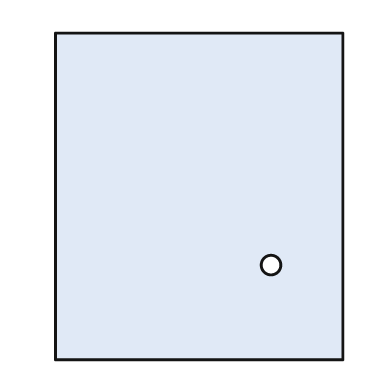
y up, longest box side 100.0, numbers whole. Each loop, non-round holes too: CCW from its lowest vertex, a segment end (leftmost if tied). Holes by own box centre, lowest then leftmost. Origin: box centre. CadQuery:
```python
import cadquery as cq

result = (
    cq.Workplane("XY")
    .moveTo(-44.0, -50.0)
    .lineTo(44.0, -50.0)
    .lineTo(44.0, 50.0)
    .lineTo(-44.0, 50.0)
    .close()
    .moveTo(22.0, -21.0)
    .circle(3.0)
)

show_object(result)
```